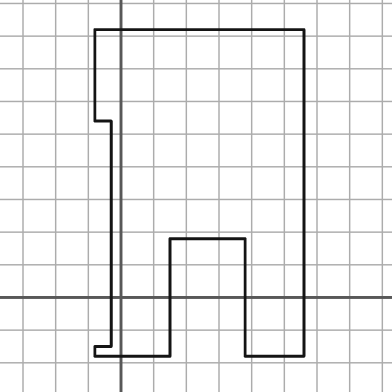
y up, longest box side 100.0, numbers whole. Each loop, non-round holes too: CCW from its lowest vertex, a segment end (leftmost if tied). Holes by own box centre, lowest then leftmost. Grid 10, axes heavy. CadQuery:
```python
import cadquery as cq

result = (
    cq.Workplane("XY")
    .moveTo(-8.0, -18.0)
    .lineTo(15.0, -18.0)
    .lineTo(15.0, 18.0)
    .lineTo(38.0, 18.0)
    .lineTo(38.0, -18.0)
    .lineTo(56.0, -18.0)
    .lineTo(56.0, 82.0)
    .lineTo(-8.0, 82.0)
    .lineTo(-8.0, 54.0)
    .lineTo(-3.0, 54.0)
    .lineTo(-3.0, -15.0)
    .lineTo(-8.0, -15.0)
    .close()
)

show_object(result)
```